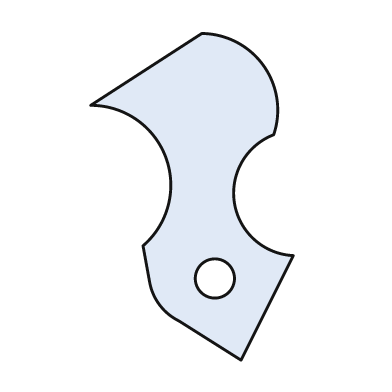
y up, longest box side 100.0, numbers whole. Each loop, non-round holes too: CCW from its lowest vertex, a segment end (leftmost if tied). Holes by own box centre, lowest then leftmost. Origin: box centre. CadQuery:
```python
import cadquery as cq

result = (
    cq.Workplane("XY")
    .moveTo(15.0, -50.0)
    .lineTo(31.0, -18.0)
    .threePointArc((13.0, -2.0), (25.0, 19.0))
    .threePointArc((22.0, 40.0), (3.0, 50.0))
    .lineTo(-31.0, 28.0)
    .threePointArc((-8.0, 12.0), (-15.0, -15.0))
    .lineTo(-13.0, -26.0)
    .threePointArc((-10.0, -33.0), (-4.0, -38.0))
    .close()
    .moveTo(7.0, -25.0)
    .circle(6.0)
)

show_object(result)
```